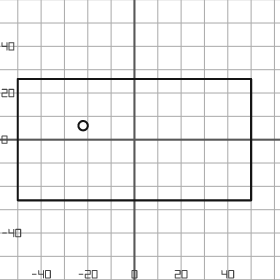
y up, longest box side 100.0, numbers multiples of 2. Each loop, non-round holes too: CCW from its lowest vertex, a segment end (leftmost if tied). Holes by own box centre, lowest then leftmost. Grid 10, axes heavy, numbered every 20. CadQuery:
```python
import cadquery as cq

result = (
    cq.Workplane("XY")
    .moveTo(-50.0, -26.0)
    .lineTo(50.0, -26.0)
    .lineTo(50.0, 26.0)
    .lineTo(-50.0, 26.0)
    .close()
    .moveTo(-22.0, 6.0)
    .circle(2.0)
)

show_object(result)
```